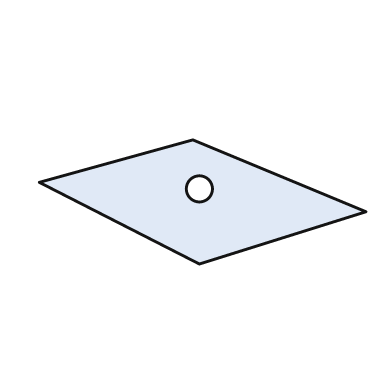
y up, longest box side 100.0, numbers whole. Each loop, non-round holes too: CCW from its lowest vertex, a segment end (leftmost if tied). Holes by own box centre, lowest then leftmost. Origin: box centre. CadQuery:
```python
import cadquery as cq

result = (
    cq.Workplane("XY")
    .moveTo(-1.0, -19.0)
    .lineTo(50.0, -3.0)
    .lineTo(-3.0, 19.0)
    .lineTo(-50.0, 6.0)
    .close()
    .moveTo(-1.0, 4.0)
    .circle(4.0)
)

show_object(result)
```